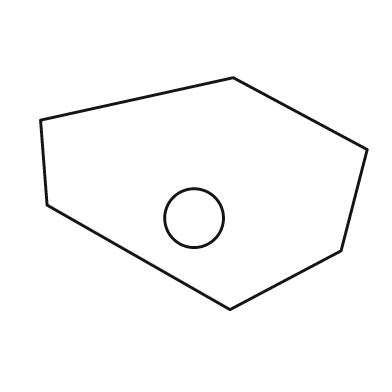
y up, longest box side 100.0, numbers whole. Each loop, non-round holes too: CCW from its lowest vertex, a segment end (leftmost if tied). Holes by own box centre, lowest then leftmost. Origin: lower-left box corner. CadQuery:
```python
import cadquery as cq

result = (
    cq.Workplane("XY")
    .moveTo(58.0, 0.0)
    .lineTo(92.0, 18.0)
    .lineTo(100.0, 49.0)
    .lineTo(59.0, 71.0)
    .lineTo(0.0, 58.0)
    .lineTo(2.0, 32.0)
    .close()
    .moveTo(47.0, 28.0)
    .circle(9.0)
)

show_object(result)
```